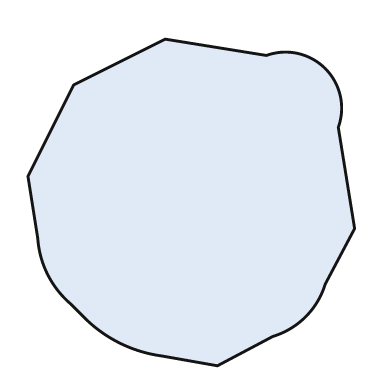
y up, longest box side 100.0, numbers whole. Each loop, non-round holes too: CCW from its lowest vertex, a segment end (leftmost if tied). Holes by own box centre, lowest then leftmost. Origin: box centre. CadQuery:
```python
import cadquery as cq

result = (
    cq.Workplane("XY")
    .moveTo(8.0, -50.0)
    .lineTo(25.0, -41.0)
    .threePointArc((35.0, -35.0), (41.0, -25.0))
    .lineTo(50.0, -8.0)
    .lineTo(45.0, 23.0)
    .threePointArc((41.0, 41.0), (23.0, 45.0))
    .lineTo(-8.0, 50.0)
    .lineTo(-36.0, 36.0)
    .lineTo(-50.0, 8.0)
    .lineTo(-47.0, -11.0)
    .threePointArc((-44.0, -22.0), (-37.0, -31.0))
    .lineTo(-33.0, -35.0)
    .threePointArc((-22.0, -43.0), (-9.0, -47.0))
    .close()
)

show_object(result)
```